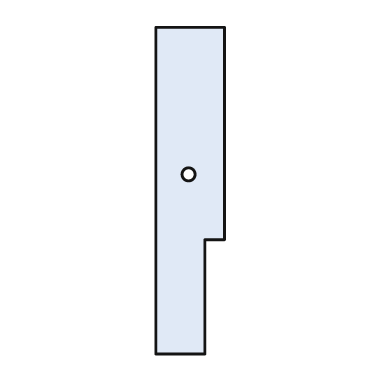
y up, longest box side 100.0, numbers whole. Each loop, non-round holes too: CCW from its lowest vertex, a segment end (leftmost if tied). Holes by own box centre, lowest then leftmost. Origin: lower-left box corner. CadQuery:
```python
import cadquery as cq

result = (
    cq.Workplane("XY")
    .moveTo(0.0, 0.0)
    .lineTo(15.0, 0.0)
    .lineTo(15.0, 35.0)
    .lineTo(21.0, 35.0)
    .lineTo(21.0, 100.0)
    .lineTo(0.0, 100.0)
    .close()
    .moveTo(10.0, 55.0)
    .circle(2.0)
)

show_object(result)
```